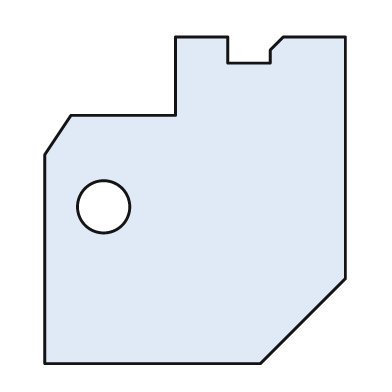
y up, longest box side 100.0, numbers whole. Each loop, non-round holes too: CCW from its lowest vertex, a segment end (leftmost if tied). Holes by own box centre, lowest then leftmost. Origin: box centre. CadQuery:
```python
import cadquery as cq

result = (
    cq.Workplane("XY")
    .moveTo(-46.0, -50.0)
    .lineTo(20.0, -50.0)
    .lineTo(46.0, -24.0)
    .lineTo(46.0, 50.0)
    .lineTo(27.0, 50.0)
    .lineTo(23.0, 46.0)
    .lineTo(23.0, 42.0)
    .lineTo(10.0, 42.0)
    .lineTo(10.0, 50.0)
    .lineTo(-6.0, 50.0)
    .lineTo(-6.0, 26.0)
    .lineTo(-38.0, 26.0)
    .lineTo(-46.0, 14.0)
    .close()
    .moveTo(-28.0, -2.0)
    .circle(8.0)
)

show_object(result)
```